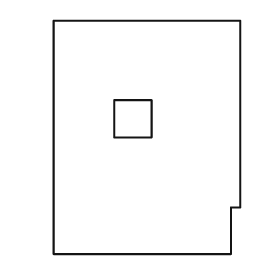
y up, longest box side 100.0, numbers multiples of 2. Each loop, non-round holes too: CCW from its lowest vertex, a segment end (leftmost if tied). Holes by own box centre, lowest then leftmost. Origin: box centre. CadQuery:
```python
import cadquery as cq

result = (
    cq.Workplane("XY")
    .moveTo(-40.0, -50.0)
    .lineTo(36.0, -50.0)
    .lineTo(36.0, -30.0)
    .lineTo(40.0, -30.0)
    .lineTo(40.0, 50.0)
    .lineTo(-40.0, 50.0)
    .close()
    .moveTo(-14.0, 0.0)
    .lineTo(2.0, 0.0)
    .lineTo(2.0, 16.0)
    .lineTo(-14.0, 16.0)
    .close()
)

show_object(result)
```